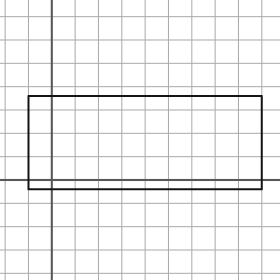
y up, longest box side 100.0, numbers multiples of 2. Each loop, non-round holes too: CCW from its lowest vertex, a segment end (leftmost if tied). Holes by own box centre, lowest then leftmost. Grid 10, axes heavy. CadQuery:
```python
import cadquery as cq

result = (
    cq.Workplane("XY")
    .moveTo(-10.0, -4.0)
    .lineTo(90.0, -4.0)
    .lineTo(90.0, 36.0)
    .lineTo(-10.0, 36.0)
    .close()
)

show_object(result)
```